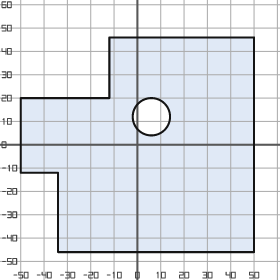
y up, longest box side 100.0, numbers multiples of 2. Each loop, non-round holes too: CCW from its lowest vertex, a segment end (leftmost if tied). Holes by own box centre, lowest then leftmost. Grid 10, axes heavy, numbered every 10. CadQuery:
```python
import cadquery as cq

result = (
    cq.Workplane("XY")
    .moveTo(-34.0, -46.0)
    .lineTo(50.0, -46.0)
    .lineTo(50.0, 46.0)
    .lineTo(-12.0, 46.0)
    .lineTo(-12.0, 20.0)
    .lineTo(-50.0, 20.0)
    .lineTo(-50.0, -12.0)
    .lineTo(-34.0, -12.0)
    .close()
    .moveTo(6.0, 12.0)
    .circle(8.0)
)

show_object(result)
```